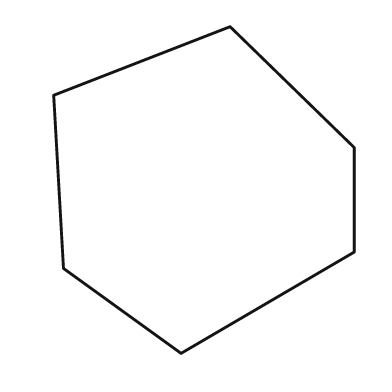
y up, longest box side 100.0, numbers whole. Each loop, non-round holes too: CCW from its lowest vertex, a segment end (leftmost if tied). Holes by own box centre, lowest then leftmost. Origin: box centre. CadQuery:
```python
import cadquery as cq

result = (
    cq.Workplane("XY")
    .moveTo(-7.0, -50.0)
    .lineTo(46.0, -19.0)
    .lineTo(46.0, 13.0)
    .lineTo(8.0, 50.0)
    .lineTo(-46.0, 29.0)
    .lineTo(-43.0, -24.0)
    .close()
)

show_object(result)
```